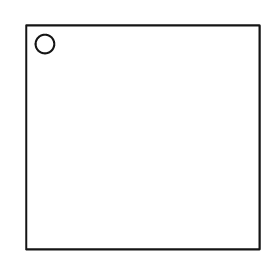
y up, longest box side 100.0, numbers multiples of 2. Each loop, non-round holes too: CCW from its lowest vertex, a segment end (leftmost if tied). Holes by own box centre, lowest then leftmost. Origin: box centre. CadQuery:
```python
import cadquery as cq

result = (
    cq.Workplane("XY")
    .moveTo(-50.0, -48.0)
    .lineTo(50.0, -48.0)
    .lineTo(50.0, 48.0)
    .lineTo(-50.0, 48.0)
    .close()
    .moveTo(-42.0, 40.0)
    .circle(4.0)
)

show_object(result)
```